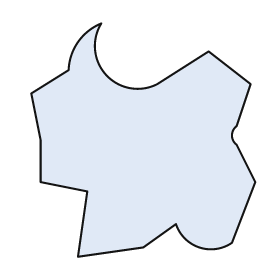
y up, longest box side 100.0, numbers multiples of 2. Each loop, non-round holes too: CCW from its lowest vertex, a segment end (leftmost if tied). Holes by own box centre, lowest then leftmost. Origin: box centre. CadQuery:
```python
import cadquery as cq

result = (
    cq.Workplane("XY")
    .moveTo(-28.0, -50.0)
    .lineTo(0.0, -46.0)
    .lineTo(14.0, -36.0)
    .threePointArc((24.0, -46.0), (38.0, -44.0))
    .lineTo(48.0, -18.0)
    .lineTo(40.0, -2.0)
    .threePointArc((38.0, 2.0), (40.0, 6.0))
    .lineTo(46.0, 24.0)
    .lineTo(28.0, 38.0)
    .lineTo(6.0, 24.0)
    .threePointArc((-16.0, 28.0), (-18.0, 50.0))
    .threePointArc((-28.0, 42.0), (-32.0, 30.0))
    .lineTo(-48.0, 20.0)
    .lineTo(-44.0, 0.0)
    .lineTo(-44.0, -18.0)
    .lineTo(-24.0, -22.0)
    .close()
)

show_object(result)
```